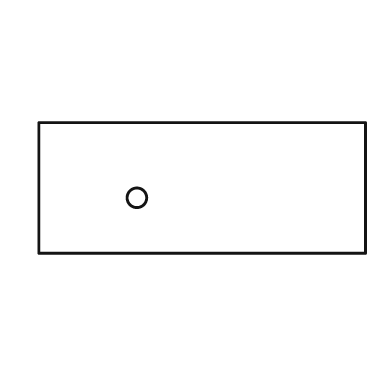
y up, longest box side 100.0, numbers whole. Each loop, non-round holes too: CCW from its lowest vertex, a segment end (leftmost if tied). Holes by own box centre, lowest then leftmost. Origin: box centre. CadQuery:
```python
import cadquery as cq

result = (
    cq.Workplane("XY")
    .moveTo(-50.0, -20.0)
    .lineTo(50.0, -20.0)
    .lineTo(50.0, 20.0)
    .lineTo(-50.0, 20.0)
    .close()
    .moveTo(-20.0, -3.0)
    .circle(3.0)
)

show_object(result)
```